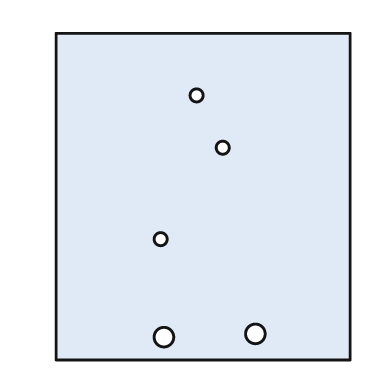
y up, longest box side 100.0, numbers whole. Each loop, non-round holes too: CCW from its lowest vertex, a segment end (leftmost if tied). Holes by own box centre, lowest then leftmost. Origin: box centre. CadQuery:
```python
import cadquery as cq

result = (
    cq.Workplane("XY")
    .moveTo(-45.0, -50.0)
    .lineTo(45.0, -50.0)
    .lineTo(45.0, 50.0)
    .lineTo(-45.0, 50.0)
    .close()
    .moveTo(-12.0, -43.0)
    .circle(3.0)
    .moveTo(16.0, -42.0)
    .circle(3.0)
    .moveTo(-13.0, -13.0)
    .circle(2.0)
    .moveTo(6.0, 15.0)
    .circle(2.0)
    .moveTo(-2.0, 31.0)
    .circle(2.0)
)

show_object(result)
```